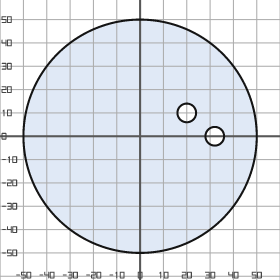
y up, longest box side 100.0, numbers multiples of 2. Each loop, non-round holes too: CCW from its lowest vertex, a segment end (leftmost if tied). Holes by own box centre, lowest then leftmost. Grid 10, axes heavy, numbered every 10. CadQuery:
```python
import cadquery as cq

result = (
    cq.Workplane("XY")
    .moveTo(0.0, 0.0)
    .circle(50.0)
    .moveTo(32.0, 0.0)
    .circle(4.0)
    .moveTo(20.0, 10.0)
    .circle(4.0)
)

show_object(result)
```